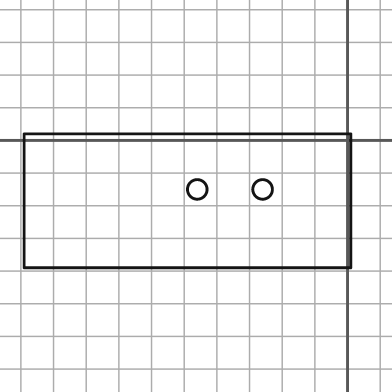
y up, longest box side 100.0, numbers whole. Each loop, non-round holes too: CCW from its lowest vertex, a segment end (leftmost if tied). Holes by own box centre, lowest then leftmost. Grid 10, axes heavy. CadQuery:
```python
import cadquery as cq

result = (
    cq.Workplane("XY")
    .moveTo(-99.0, -39.0)
    .lineTo(1.0, -39.0)
    .lineTo(1.0, 2.0)
    .lineTo(-99.0, 2.0)
    .close()
    .moveTo(-46.0, -15.0)
    .circle(3.0)
    .moveTo(-26.0, -15.0)
    .circle(3.0)
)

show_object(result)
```